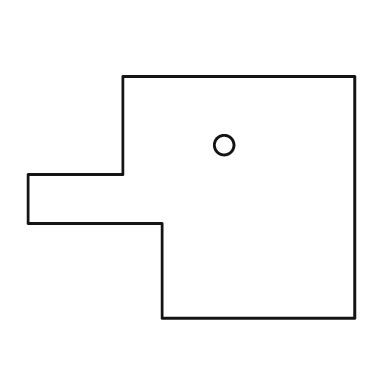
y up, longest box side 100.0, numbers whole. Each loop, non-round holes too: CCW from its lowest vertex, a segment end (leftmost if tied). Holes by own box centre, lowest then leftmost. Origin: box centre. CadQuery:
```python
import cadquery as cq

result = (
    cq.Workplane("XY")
    .moveTo(-9.0, -37.0)
    .lineTo(50.0, -37.0)
    .lineTo(50.0, 37.0)
    .lineTo(-21.0, 37.0)
    .lineTo(-21.0, 7.0)
    .lineTo(-50.0, 7.0)
    .lineTo(-50.0, -8.0)
    .lineTo(-9.0, -8.0)
    .close()
    .moveTo(10.0, 16.0)
    .circle(3.0)
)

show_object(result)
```